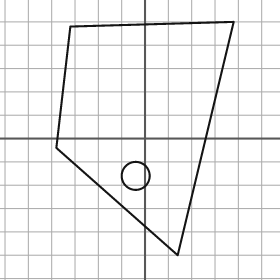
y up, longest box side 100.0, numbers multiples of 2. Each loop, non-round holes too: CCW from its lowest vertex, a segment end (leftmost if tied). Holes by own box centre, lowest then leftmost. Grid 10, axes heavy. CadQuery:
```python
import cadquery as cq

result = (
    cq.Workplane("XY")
    .moveTo(14.0, -50.0)
    .lineTo(38.0, 50.0)
    .lineTo(-32.0, 48.0)
    .lineTo(-38.0, -4.0)
    .close()
    .moveTo(-4.0, -16.0)
    .circle(6.0)
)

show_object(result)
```